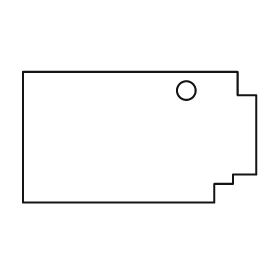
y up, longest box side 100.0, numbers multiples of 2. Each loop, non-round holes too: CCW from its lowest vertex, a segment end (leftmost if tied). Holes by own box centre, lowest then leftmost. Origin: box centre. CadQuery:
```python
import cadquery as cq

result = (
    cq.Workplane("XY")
    .moveTo(-50.0, -28.0)
    .lineTo(32.0, -28.0)
    .lineTo(32.0, -20.0)
    .lineTo(40.0, -20.0)
    .lineTo(40.0, -16.0)
    .lineTo(50.0, -16.0)
    .lineTo(50.0, 18.0)
    .lineTo(42.0, 18.0)
    .lineTo(42.0, 28.0)
    .lineTo(-50.0, 28.0)
    .close()
    .moveTo(20.0, 20.0)
    .circle(4.0)
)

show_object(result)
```